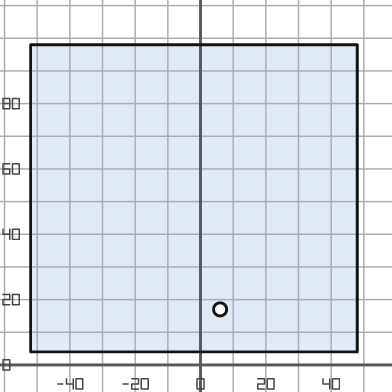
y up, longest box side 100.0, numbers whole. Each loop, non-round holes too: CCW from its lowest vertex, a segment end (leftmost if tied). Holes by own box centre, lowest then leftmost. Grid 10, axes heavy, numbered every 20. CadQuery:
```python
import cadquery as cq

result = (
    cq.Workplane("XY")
    .moveTo(-52.0, 4.0)
    .lineTo(48.0, 4.0)
    .lineTo(48.0, 98.0)
    .lineTo(-52.0, 98.0)
    .close()
    .moveTo(6.0, 17.0)
    .circle(2.0)
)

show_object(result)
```